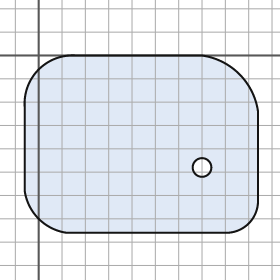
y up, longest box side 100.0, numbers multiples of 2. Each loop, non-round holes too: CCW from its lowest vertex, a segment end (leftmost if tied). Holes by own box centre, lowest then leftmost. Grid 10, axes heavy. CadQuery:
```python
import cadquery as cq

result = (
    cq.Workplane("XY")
    .moveTo(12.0, -76.0)
    .lineTo(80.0, -76.0)
    .threePointArc((90.0, -72.0), (94.0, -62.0))
    .lineTo(94.0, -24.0)
    .threePointArc((86.0, -8.0), (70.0, 0.0))
    .lineTo(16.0, 0.0)
    .threePointArc((0.0, -6.0), (-6.0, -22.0))
    .lineTo(-6.0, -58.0)
    .threePointArc((0.0, -70.0), (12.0, -76.0))
    .close()
    .moveTo(70.0, -48.0)
    .circle(4.0)
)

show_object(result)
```